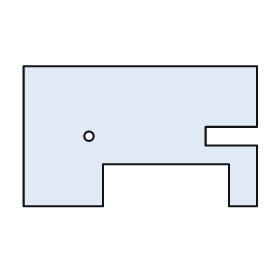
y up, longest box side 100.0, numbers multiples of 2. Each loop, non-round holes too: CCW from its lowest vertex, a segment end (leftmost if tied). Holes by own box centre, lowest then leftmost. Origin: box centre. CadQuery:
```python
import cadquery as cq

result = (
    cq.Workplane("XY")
    .moveTo(-50.0, -30.0)
    .lineTo(-16.0, -30.0)
    .lineTo(-16.0, -12.0)
    .lineTo(38.0, -12.0)
    .lineTo(38.0, -30.0)
    .lineTo(50.0, -30.0)
    .lineTo(50.0, -4.0)
    .lineTo(28.0, -4.0)
    .lineTo(28.0, 4.0)
    .lineTo(50.0, 4.0)
    .lineTo(50.0, 30.0)
    .lineTo(-50.0, 30.0)
    .close()
    .moveTo(-22.0, 0.0)
    .circle(2.0)
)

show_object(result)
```